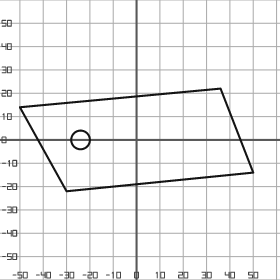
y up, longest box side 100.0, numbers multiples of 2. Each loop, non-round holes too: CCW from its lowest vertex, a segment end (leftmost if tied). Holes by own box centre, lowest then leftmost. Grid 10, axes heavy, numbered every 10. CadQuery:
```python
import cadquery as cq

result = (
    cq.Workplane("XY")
    .moveTo(-30.0, -22.0)
    .lineTo(50.0, -14.0)
    .lineTo(36.0, 22.0)
    .lineTo(-50.0, 14.0)
    .close()
    .moveTo(-24.0, 0.0)
    .circle(4.0)
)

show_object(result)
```